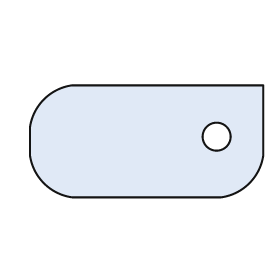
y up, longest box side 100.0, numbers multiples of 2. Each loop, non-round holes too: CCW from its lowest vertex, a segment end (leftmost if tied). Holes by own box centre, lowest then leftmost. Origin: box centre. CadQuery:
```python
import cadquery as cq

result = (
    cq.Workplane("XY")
    .moveTo(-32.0, -24.0)
    .lineTo(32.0, -24.0)
    .threePointArc((44.0, -18.0), (50.0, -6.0))
    .lineTo(50.0, 24.0)
    .lineTo(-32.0, 24.0)
    .threePointArc((-44.0, 18.0), (-50.0, 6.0))
    .lineTo(-50.0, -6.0)
    .threePointArc((-44.0, -18.0), (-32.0, -24.0))
    .close()
    .moveTo(30.0, 2.0)
    .circle(6.0)
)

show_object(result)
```